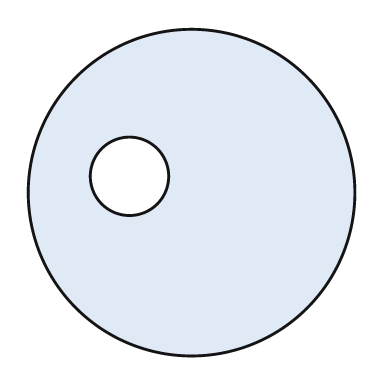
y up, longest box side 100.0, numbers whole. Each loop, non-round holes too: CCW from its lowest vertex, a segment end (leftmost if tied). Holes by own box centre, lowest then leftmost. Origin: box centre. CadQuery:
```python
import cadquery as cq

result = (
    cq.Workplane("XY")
    .moveTo(0.0, 0.0)
    .circle(50.0)
    .moveTo(-19.0, 5.0)
    .circle(12.0)
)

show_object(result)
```